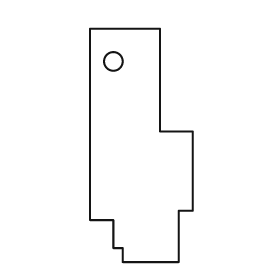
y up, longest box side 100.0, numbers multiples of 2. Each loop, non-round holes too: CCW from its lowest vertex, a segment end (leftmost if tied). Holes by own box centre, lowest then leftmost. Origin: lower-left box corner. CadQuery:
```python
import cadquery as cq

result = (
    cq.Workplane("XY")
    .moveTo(14.0, 0.0)
    .lineTo(38.0, 0.0)
    .lineTo(38.0, 22.0)
    .lineTo(44.0, 22.0)
    .lineTo(44.0, 56.0)
    .lineTo(30.0, 56.0)
    .lineTo(30.0, 100.0)
    .lineTo(0.0, 100.0)
    .lineTo(0.0, 18.0)
    .lineTo(10.0, 18.0)
    .lineTo(10.0, 6.0)
    .lineTo(14.0, 6.0)
    .close()
    .moveTo(10.0, 86.0)
    .circle(4.0)
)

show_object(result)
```